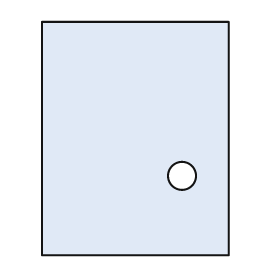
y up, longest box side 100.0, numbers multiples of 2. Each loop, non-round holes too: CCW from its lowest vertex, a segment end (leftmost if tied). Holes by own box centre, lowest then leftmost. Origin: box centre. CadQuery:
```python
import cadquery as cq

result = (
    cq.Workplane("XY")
    .moveTo(-40.0, -50.0)
    .lineTo(40.0, -50.0)
    .lineTo(40.0, 50.0)
    .lineTo(-40.0, 50.0)
    .close()
    .moveTo(20.0, -16.0)
    .circle(6.0)
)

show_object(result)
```